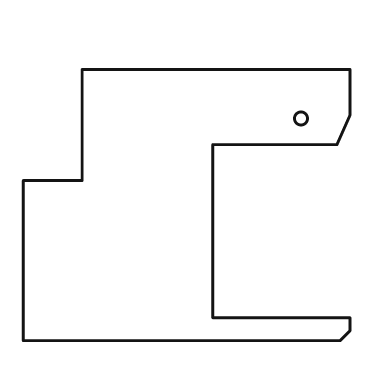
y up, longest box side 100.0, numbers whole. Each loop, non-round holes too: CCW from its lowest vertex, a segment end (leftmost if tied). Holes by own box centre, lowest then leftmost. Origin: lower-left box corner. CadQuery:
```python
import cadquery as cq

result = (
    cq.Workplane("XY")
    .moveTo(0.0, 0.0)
    .lineTo(97.0, 0.0)
    .lineTo(100.0, 3.0)
    .lineTo(100.0, 7.0)
    .lineTo(58.0, 7.0)
    .lineTo(58.0, 60.0)
    .lineTo(96.0, 60.0)
    .lineTo(100.0, 69.0)
    .lineTo(100.0, 83.0)
    .lineTo(18.0, 83.0)
    .lineTo(18.0, 49.0)
    .lineTo(0.0, 49.0)
    .close()
    .moveTo(85.0, 68.0)
    .circle(2.0)
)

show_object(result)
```